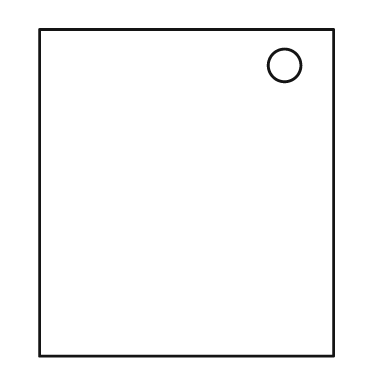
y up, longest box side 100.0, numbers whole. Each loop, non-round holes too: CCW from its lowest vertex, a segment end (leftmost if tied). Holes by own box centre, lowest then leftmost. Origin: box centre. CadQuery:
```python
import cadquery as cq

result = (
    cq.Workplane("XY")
    .moveTo(-45.0, -50.0)
    .lineTo(45.0, -50.0)
    .lineTo(45.0, 50.0)
    .lineTo(-45.0, 50.0)
    .close()
    .moveTo(30.0, 39.0)
    .circle(5.0)
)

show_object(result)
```